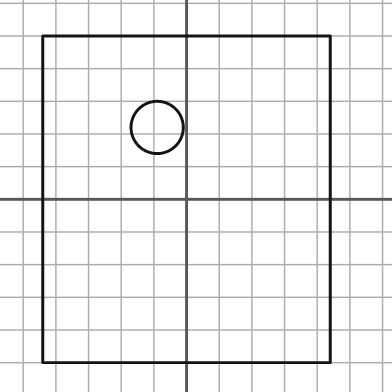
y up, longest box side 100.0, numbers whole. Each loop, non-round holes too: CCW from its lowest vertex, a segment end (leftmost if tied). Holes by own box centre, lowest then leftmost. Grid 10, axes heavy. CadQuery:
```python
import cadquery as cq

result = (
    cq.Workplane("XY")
    .moveTo(-44.0, -50.0)
    .lineTo(44.0, -50.0)
    .lineTo(44.0, 50.0)
    .lineTo(-44.0, 50.0)
    .close()
    .moveTo(-9.0, 22.0)
    .circle(8.0)
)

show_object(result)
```